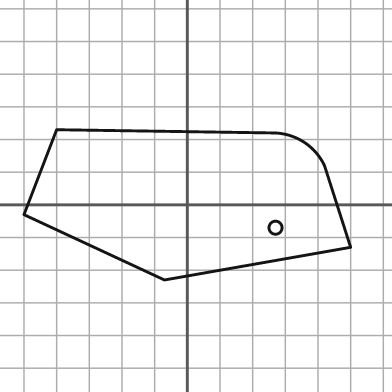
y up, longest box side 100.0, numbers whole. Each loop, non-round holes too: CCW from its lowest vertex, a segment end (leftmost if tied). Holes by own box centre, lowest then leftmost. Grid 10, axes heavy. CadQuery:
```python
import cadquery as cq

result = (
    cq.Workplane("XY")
    .moveTo(-7.0, -23.0)
    .lineTo(50.0, -13.0)
    .lineTo(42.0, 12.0)
    .threePointArc((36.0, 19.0), (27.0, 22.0))
    .lineTo(-40.0, 23.0)
    .lineTo(-50.0, -3.0)
    .close()
    .moveTo(27.0, -7.0)
    .circle(2.0)
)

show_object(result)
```